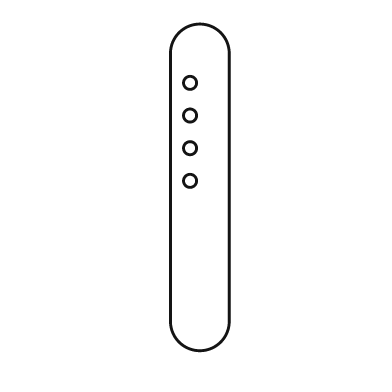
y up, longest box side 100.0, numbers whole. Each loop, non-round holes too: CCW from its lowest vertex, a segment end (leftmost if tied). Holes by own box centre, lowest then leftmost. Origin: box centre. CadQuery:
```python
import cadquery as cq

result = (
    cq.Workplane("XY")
    .moveTo(-9.0, -41.0)
    .threePointArc((0.0, -50.0), (9.0, -41.0))
    .lineTo(9.0, 41.0)
    .threePointArc((0.0, 50.0), (-9.0, 41.0))
    .close()
    .moveTo(-3.0, 2.0)
    .circle(2.0)
    .moveTo(-3.0, 12.0)
    .circle(2.0)
    .moveTo(-3.0, 22.0)
    .circle(2.0)
    .moveTo(-3.0, 32.0)
    .circle(2.0)
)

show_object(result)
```